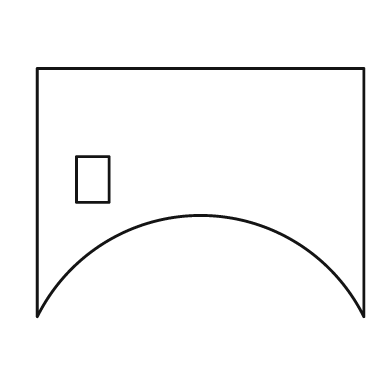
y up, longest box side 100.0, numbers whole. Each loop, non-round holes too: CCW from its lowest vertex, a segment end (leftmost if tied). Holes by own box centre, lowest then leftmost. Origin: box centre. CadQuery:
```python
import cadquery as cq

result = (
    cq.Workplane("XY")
    .moveTo(-50.0, -38.0)
    .threePointArc((0.0, -7.0), (50.0, -38.0))
    .lineTo(50.0, 38.0)
    .lineTo(-50.0, 38.0)
    .close()
    .moveTo(-38.0, -3.0)
    .lineTo(-28.0, -3.0)
    .lineTo(-28.0, 11.0)
    .lineTo(-38.0, 11.0)
    .close()
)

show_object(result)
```